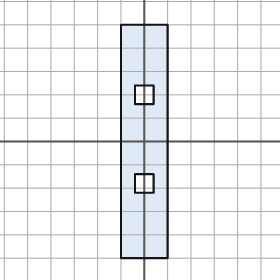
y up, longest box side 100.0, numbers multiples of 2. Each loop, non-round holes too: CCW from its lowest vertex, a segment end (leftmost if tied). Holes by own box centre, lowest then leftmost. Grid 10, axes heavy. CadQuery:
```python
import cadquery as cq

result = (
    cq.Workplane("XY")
    .moveTo(-10.0, -50.0)
    .lineTo(10.0, -50.0)
    .lineTo(10.0, 50.0)
    .lineTo(-10.0, 50.0)
    .close()
    .moveTo(-4.0, -22.0)
    .lineTo(4.0, -22.0)
    .lineTo(4.0, -14.0)
    .lineTo(-4.0, -14.0)
    .close()
    .moveTo(-4.0, 16.0)
    .lineTo(4.0, 16.0)
    .lineTo(4.0, 24.0)
    .lineTo(-4.0, 24.0)
    .close()
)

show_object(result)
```